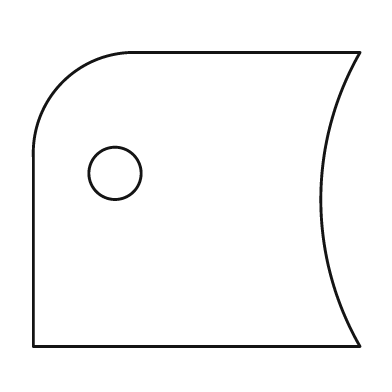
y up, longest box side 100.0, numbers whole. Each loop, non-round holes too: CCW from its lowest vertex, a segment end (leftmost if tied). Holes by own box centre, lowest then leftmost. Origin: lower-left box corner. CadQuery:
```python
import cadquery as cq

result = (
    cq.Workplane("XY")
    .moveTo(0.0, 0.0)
    .lineTo(100.0, 0.0)
    .threePointArc((88.0, 45.0), (100.0, 90.0))
    .lineTo(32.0, 90.0)
    .threePointArc((9.0, 81.0), (0.0, 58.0))
    .close()
    .moveTo(25.0, 53.0)
    .circle(8.0)
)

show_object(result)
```